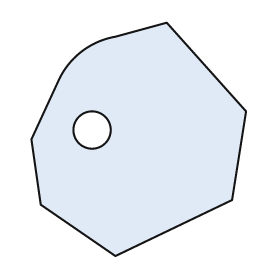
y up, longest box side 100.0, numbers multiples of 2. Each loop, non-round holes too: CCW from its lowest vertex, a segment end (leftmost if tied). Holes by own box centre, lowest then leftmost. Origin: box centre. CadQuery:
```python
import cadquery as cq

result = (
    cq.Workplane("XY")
    .moveTo(-10.0, -50.0)
    .lineTo(40.0, -26.0)
    .lineTo(46.0, 12.0)
    .lineTo(12.0, 50.0)
    .lineTo(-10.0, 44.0)
    .threePointArc((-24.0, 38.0), (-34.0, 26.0))
    .lineTo(-46.0, 0.0)
    .lineTo(-42.0, -28.0)
    .close()
    .moveTo(-20.0, 4.0)
    .circle(8.0)
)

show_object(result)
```